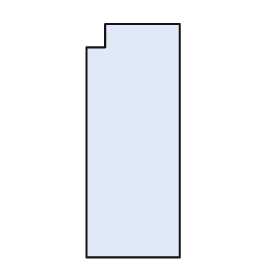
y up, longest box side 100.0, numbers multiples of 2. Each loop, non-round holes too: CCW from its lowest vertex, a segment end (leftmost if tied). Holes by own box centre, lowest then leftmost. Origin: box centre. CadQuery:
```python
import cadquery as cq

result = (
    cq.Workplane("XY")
    .moveTo(-20.0, -50.0)
    .lineTo(20.0, -50.0)
    .lineTo(20.0, 50.0)
    .lineTo(-12.0, 50.0)
    .lineTo(-12.0, 40.0)
    .lineTo(-20.0, 40.0)
    .close()
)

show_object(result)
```